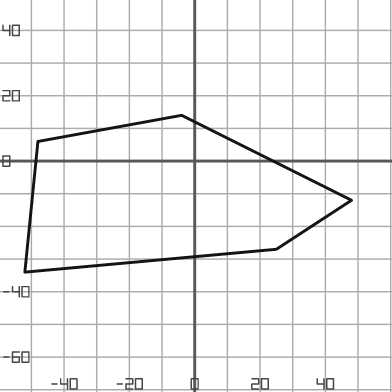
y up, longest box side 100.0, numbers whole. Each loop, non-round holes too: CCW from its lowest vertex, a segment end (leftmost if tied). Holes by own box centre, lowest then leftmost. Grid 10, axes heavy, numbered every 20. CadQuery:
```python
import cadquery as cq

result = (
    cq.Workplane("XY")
    .moveTo(-52.0, -34.0)
    .lineTo(25.0, -27.0)
    .lineTo(48.0, -12.0)
    .lineTo(-4.0, 14.0)
    .lineTo(-48.0, 6.0)
    .close()
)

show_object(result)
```